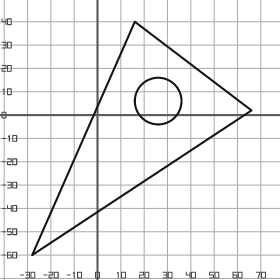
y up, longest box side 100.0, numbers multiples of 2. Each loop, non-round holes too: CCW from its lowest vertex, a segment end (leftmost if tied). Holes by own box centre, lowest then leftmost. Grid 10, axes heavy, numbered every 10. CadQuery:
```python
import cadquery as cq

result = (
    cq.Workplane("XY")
    .moveTo(-28.0, -60.0)
    .lineTo(66.0, 2.0)
    .lineTo(16.0, 40.0)
    .close()
    .moveTo(26.0, 6.0)
    .circle(10.0)
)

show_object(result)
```